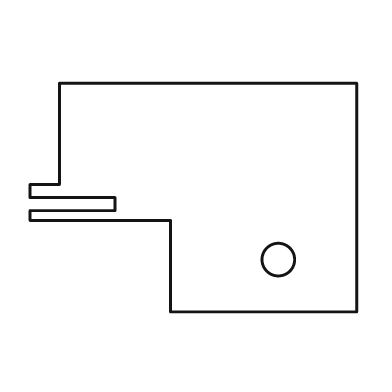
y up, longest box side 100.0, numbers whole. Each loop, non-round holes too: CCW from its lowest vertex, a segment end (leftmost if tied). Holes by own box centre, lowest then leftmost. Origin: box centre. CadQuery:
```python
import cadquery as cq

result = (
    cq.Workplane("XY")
    .moveTo(-7.0, -35.0)
    .lineTo(50.0, -35.0)
    .lineTo(50.0, 35.0)
    .lineTo(-41.0, 35.0)
    .lineTo(-41.0, 4.0)
    .lineTo(-50.0, 4.0)
    .lineTo(-50.0, 0.0)
    .lineTo(-24.0, 0.0)
    .lineTo(-24.0, -4.0)
    .lineTo(-50.0, -4.0)
    .lineTo(-50.0, -7.0)
    .lineTo(-7.0, -7.0)
    .close()
    .moveTo(26.0, -19.0)
    .circle(5.0)
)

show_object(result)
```